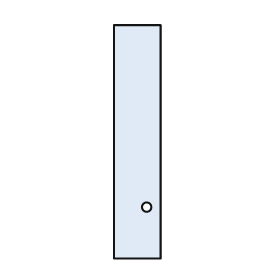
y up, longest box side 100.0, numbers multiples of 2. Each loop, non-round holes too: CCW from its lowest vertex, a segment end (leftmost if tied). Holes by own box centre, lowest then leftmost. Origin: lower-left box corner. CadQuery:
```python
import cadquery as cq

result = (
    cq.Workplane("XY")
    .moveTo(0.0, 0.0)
    .lineTo(20.0, 0.0)
    .lineTo(20.0, 100.0)
    .lineTo(0.0, 100.0)
    .close()
    .moveTo(14.0, 22.0)
    .circle(2.0)
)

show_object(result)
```